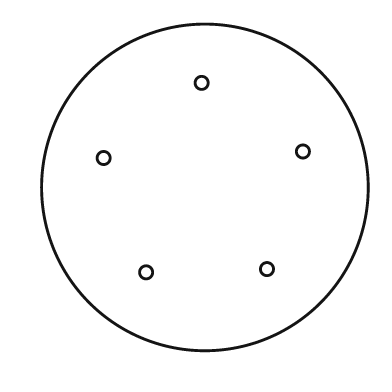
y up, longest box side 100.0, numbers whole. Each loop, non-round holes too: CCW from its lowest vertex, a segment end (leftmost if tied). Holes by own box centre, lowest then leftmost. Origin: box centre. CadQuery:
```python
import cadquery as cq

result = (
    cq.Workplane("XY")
    .moveTo(0.0, 0.0)
    .circle(50.0)
    .moveTo(-18.0, -26.0)
    .circle(2.0)
    .moveTo(19.0, -25.0)
    .circle(2.0)
    .moveTo(-31.0, 9.0)
    .circle(2.0)
    .moveTo(30.0, 11.0)
    .circle(2.0)
    .moveTo(-1.0, 32.0)
    .circle(2.0)
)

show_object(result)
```